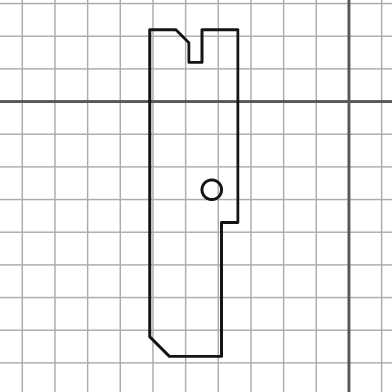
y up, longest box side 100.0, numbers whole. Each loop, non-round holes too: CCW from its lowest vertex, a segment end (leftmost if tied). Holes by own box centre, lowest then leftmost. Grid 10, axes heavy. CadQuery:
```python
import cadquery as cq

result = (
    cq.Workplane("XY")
    .moveTo(-55.0, -78.0)
    .lineTo(-39.0, -78.0)
    .lineTo(-39.0, -37.0)
    .lineTo(-34.0, -37.0)
    .lineTo(-34.0, 22.0)
    .lineTo(-45.0, 22.0)
    .lineTo(-45.0, 12.0)
    .lineTo(-49.0, 12.0)
    .lineTo(-49.0, 18.0)
    .lineTo(-53.0, 22.0)
    .lineTo(-61.0, 22.0)
    .lineTo(-61.0, -72.0)
    .close()
    .moveTo(-42.0, -27.0)
    .circle(3.0)
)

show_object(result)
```